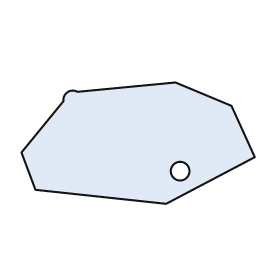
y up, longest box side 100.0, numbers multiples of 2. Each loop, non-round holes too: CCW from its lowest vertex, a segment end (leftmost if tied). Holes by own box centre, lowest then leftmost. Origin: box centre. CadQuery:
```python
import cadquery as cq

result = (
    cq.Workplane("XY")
    .moveTo(12.0, -26.0)
    .lineTo(50.0, -6.0)
    .lineTo(40.0, 16.0)
    .lineTo(16.0, 26.0)
    .lineTo(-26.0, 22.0)
    .threePointArc((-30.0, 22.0), (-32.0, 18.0))
    .lineTo(-50.0, -4.0)
    .lineTo(-44.0, -20.0)
    .close()
    .moveTo(18.0, -12.0)
    .circle(4.0)
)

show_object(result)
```